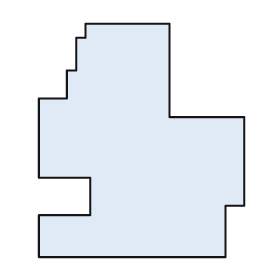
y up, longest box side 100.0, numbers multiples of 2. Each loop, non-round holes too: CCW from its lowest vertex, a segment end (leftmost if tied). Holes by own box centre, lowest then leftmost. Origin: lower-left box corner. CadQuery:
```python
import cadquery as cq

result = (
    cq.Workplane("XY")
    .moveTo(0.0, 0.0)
    .lineTo(80.0, 0.0)
    .lineTo(80.0, 22.0)
    .lineTo(88.0, 22.0)
    .lineTo(88.0, 60.0)
    .lineTo(56.0, 60.0)
    .lineTo(56.0, 100.0)
    .lineTo(20.0, 100.0)
    .lineTo(20.0, 94.0)
    .lineTo(16.0, 94.0)
    .lineTo(16.0, 80.0)
    .lineTo(12.0, 80.0)
    .lineTo(12.0, 68.0)
    .lineTo(0.0, 68.0)
    .lineTo(0.0, 34.0)
    .lineTo(22.0, 34.0)
    .lineTo(22.0, 18.0)
    .lineTo(0.0, 18.0)
    .close()
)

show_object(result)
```